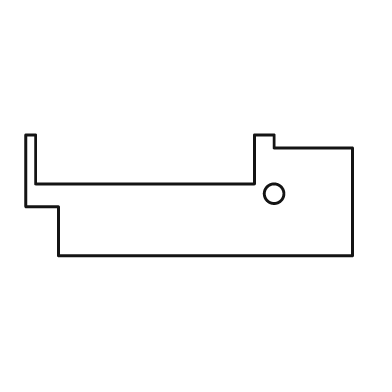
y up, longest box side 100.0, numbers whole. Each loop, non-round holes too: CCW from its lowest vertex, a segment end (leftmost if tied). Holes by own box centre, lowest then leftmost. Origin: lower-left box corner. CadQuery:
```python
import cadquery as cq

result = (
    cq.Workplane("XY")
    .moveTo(10.0, 0.0)
    .lineTo(100.0, 0.0)
    .lineTo(100.0, 33.0)
    .lineTo(76.0, 33.0)
    .lineTo(76.0, 37.0)
    .lineTo(70.0, 37.0)
    .lineTo(70.0, 22.0)
    .lineTo(3.0, 22.0)
    .lineTo(3.0, 37.0)
    .lineTo(0.0, 37.0)
    .lineTo(0.0, 15.0)
    .lineTo(10.0, 15.0)
    .close()
    .moveTo(76.0, 19.0)
    .circle(3.0)
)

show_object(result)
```